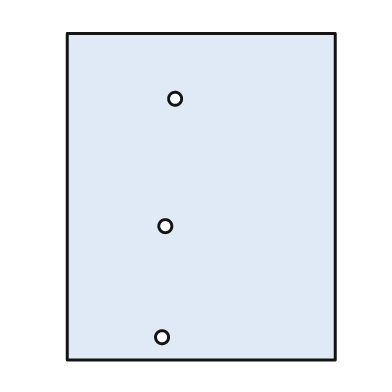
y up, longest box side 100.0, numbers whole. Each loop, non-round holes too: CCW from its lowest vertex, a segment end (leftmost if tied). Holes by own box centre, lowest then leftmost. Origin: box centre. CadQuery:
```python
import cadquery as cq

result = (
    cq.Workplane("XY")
    .moveTo(-41.0, -50.0)
    .lineTo(41.0, -50.0)
    .lineTo(41.0, 50.0)
    .lineTo(-41.0, 50.0)
    .close()
    .moveTo(-12.0, -43.0)
    .circle(2.0)
    .moveTo(-11.0, -9.0)
    .circle(2.0)
    .moveTo(-8.0, 30.0)
    .circle(2.0)
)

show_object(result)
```